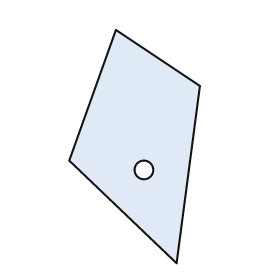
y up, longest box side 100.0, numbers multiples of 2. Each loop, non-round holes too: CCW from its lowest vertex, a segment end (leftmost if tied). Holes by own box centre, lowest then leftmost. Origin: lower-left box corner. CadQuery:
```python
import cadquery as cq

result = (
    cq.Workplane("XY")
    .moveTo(46.0, 0.0)
    .lineTo(56.0, 76.0)
    .lineTo(20.0, 100.0)
    .lineTo(0.0, 44.0)
    .close()
    .moveTo(32.0, 40.0)
    .circle(4.0)
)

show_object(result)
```